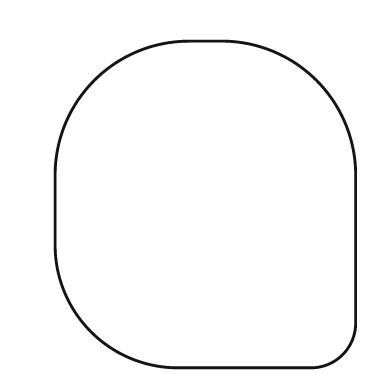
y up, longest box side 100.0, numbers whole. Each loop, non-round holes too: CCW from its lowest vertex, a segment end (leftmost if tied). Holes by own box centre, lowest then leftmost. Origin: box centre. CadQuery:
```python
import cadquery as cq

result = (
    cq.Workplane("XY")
    .moveTo(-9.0, -50.0)
    .lineTo(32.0, -50.0)
    .threePointArc((42.0, -46.0), (46.0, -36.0))
    .lineTo(46.0, 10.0)
    .threePointArc((34.0, 38.0), (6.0, 50.0))
    .lineTo(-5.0, 50.0)
    .threePointArc((-34.0, 38.0), (-46.0, 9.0))
    .lineTo(-46.0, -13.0)
    .threePointArc((-35.0, -39.0), (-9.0, -50.0))
    .close()
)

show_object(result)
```